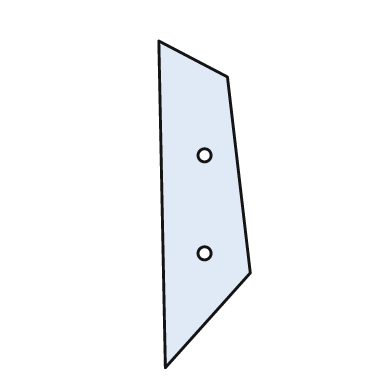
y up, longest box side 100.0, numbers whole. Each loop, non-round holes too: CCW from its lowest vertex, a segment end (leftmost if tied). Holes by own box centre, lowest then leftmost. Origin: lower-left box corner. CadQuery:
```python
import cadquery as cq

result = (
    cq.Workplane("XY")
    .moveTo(2.0, 0.0)
    .lineTo(28.0, 29.0)
    .lineTo(21.0, 89.0)
    .lineTo(0.0, 100.0)
    .close()
    .moveTo(14.0, 35.0)
    .circle(2.0)
    .moveTo(14.0, 65.0)
    .circle(2.0)
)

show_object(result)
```